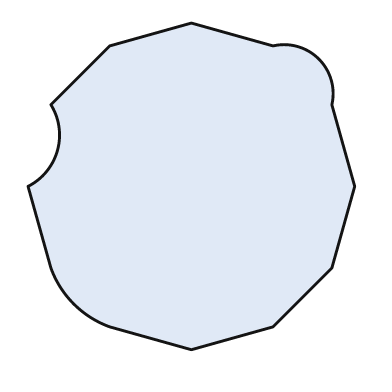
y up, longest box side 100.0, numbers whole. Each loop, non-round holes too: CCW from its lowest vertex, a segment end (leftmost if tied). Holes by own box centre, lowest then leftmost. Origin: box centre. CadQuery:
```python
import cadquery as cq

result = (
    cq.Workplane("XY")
    .moveTo(0.0, -50.0)
    .lineTo(25.0, -43.0)
    .lineTo(43.0, -25.0)
    .lineTo(50.0, 0.0)
    .lineTo(43.0, 25.0)
    .threePointArc((39.0, 39.0), (25.0, 43.0))
    .lineTo(0.0, 50.0)
    .lineTo(-25.0, 43.0)
    .lineTo(-43.0, 25.0)
    .threePointArc((-41.0, 11.0), (-50.0, 0.0))
    .lineTo(-43.0, -25.0)
    .threePointArc((-36.0, -36.0), (-25.0, -43.0))
    .close()
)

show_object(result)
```